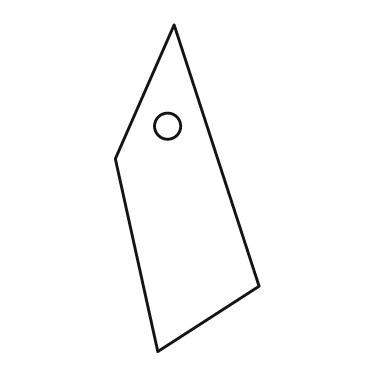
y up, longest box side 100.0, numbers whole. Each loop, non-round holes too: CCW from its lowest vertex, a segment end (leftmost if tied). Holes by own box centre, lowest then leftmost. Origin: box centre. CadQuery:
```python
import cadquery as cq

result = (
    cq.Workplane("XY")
    .moveTo(-9.0, -50.0)
    .lineTo(22.0, -30.0)
    .lineTo(-4.0, 50.0)
    .lineTo(-22.0, 9.0)
    .close()
    .moveTo(-6.0, 19.0)
    .circle(4.0)
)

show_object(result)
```